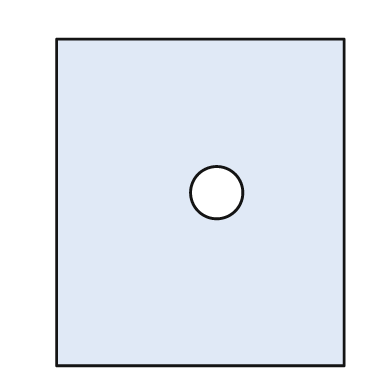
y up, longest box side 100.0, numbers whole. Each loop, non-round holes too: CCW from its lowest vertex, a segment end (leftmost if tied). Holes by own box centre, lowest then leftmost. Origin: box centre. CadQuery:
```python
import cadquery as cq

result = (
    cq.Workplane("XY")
    .moveTo(-44.0, -50.0)
    .lineTo(44.0, -50.0)
    .lineTo(44.0, 50.0)
    .lineTo(-44.0, 50.0)
    .close()
    .moveTo(5.0, 3.0)
    .circle(8.0)
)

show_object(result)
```